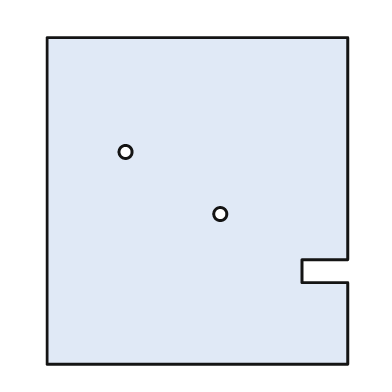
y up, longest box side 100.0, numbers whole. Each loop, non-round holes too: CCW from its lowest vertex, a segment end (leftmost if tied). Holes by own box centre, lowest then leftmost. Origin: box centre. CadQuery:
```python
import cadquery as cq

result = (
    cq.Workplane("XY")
    .moveTo(-46.0, -50.0)
    .lineTo(46.0, -50.0)
    .lineTo(46.0, -25.0)
    .lineTo(32.0, -25.0)
    .lineTo(32.0, -18.0)
    .lineTo(46.0, -18.0)
    .lineTo(46.0, 50.0)
    .lineTo(-46.0, 50.0)
    .close()
    .moveTo(7.0, -4.0)
    .circle(2.0)
    .moveTo(-22.0, 15.0)
    .circle(2.0)
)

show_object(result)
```